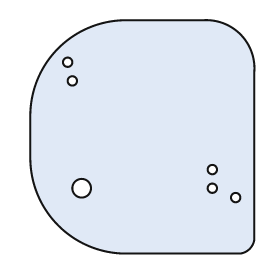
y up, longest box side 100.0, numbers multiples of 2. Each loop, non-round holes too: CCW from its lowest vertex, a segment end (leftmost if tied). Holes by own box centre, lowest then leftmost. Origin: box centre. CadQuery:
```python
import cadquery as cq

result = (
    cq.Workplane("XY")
    .moveTo(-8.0, -50.0)
    .lineTo(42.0, -50.0)
    .threePointArc((46.0, -48.0), (48.0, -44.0))
    .lineTo(48.0, 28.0)
    .threePointArc((42.0, 44.0), (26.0, 50.0))
    .lineTo(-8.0, 50.0)
    .threePointArc((-36.0, 38.0), (-48.0, 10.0))
    .lineTo(-48.0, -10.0)
    .threePointArc((-36.0, -38.0), (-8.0, -50.0))
    .close()
    .moveTo(40.0, -26.0)
    .circle(2.0)
    .moveTo(-26.0, -22.0)
    .circle(4.0)
    .moveTo(30.0, -22.0)
    .circle(2.0)
    .moveTo(30.0, -14.0)
    .circle(2.0)
    .moveTo(-30.0, 24.0)
    .circle(2.0)
    .moveTo(-32.0, 32.0)
    .circle(2.0)
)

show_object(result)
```